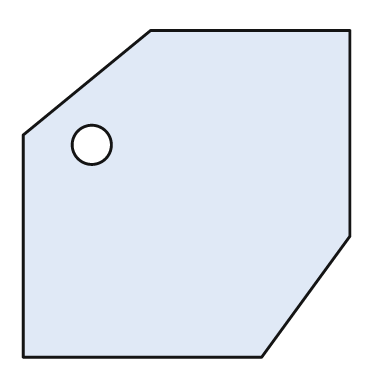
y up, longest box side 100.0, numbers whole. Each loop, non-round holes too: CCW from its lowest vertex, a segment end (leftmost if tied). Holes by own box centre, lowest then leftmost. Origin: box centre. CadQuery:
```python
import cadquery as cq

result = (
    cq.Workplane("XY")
    .moveTo(-50.0, -50.0)
    .lineTo(23.0, -50.0)
    .lineTo(50.0, -13.0)
    .lineTo(50.0, 50.0)
    .lineTo(-11.0, 50.0)
    .lineTo(-50.0, 18.0)
    .close()
    .moveTo(-29.0, 15.0)
    .circle(6.0)
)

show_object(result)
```